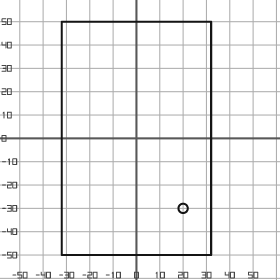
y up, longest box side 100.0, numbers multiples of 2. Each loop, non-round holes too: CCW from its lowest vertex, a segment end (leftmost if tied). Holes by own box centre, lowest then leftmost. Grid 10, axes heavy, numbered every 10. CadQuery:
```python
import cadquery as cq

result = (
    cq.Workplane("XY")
    .moveTo(-32.0, -50.0)
    .lineTo(32.0, -50.0)
    .lineTo(32.0, 50.0)
    .lineTo(-32.0, 50.0)
    .close()
    .moveTo(20.0, -30.0)
    .circle(2.0)
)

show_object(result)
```